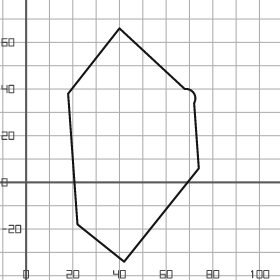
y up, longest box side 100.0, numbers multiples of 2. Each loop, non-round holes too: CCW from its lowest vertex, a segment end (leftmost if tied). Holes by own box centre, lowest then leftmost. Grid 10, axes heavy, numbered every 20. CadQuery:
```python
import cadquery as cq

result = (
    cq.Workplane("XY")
    .moveTo(42.0, -34.0)
    .lineTo(74.0, 6.0)
    .lineTo(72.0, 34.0)
    .threePointArc((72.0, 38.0), (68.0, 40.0))
    .lineTo(40.0, 66.0)
    .lineTo(18.0, 38.0)
    .lineTo(22.0, -18.0)
    .close()
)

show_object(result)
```